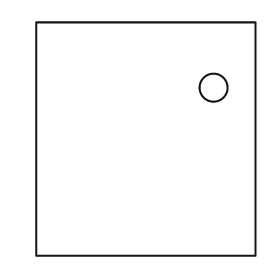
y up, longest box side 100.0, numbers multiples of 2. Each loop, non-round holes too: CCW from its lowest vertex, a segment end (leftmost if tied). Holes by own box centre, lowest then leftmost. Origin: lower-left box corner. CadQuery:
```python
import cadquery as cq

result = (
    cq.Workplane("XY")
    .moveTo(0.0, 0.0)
    .lineTo(94.0, 0.0)
    .lineTo(94.0, 100.0)
    .lineTo(0.0, 100.0)
    .close()
    .moveTo(76.0, 72.0)
    .circle(6.0)
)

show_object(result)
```